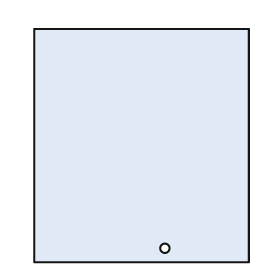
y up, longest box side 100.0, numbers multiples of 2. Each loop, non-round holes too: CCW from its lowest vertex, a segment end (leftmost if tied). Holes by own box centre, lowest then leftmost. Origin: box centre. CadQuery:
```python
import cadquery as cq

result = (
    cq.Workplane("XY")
    .moveTo(-46.0, -50.0)
    .lineTo(46.0, -50.0)
    .lineTo(46.0, 50.0)
    .lineTo(-46.0, 50.0)
    .close()
    .moveTo(10.0, -44.0)
    .circle(2.0)
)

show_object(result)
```